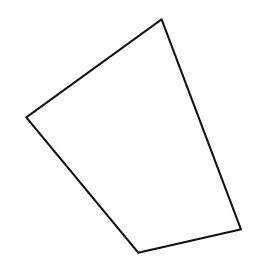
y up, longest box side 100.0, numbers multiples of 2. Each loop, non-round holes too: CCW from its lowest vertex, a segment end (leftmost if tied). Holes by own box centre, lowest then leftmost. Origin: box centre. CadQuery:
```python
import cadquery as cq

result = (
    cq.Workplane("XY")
    .moveTo(2.0, -50.0)
    .lineTo(46.0, -40.0)
    .lineTo(12.0, 50.0)
    .lineTo(-46.0, 8.0)
    .close()
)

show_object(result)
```